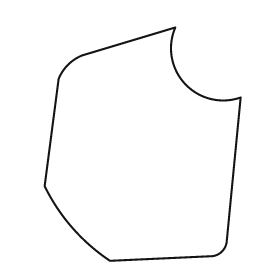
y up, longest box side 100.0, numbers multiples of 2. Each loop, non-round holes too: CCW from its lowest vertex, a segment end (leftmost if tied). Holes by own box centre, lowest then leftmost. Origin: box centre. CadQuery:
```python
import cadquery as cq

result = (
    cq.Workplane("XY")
    .moveTo(-14.0, -50.0)
    .lineTo(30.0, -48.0)
    .threePointArc((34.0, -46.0), (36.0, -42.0))
    .lineTo(42.0, 20.0)
    .threePointArc((18.0, 26.0), (14.0, 50.0))
    .lineTo(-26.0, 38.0)
    .threePointArc((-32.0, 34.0), (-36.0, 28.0))
    .lineTo(-42.0, -18.0)
    .threePointArc((-30.0, -36.0), (-14.0, -50.0))
    .close()
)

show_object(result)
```